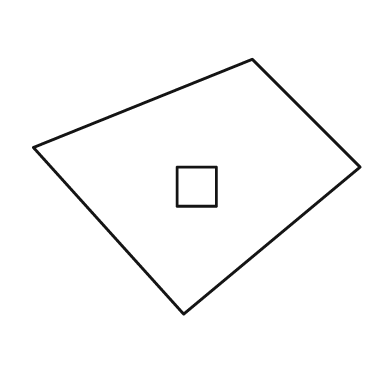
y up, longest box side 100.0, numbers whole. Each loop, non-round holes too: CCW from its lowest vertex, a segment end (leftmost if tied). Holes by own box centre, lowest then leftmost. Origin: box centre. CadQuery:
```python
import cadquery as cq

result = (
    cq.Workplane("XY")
    .moveTo(-4.0, -39.0)
    .lineTo(50.0, 6.0)
    .lineTo(17.0, 39.0)
    .lineTo(-50.0, 12.0)
    .close()
    .moveTo(-6.0, -6.0)
    .lineTo(6.0, -6.0)
    .lineTo(6.0, 6.0)
    .lineTo(-6.0, 6.0)
    .close()
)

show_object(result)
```